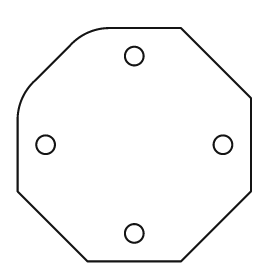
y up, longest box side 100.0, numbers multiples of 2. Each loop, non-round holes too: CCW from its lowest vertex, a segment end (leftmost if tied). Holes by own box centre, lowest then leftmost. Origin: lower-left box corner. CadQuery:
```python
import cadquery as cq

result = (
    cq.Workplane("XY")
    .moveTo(30.0, 0.0)
    .lineTo(70.0, 0.0)
    .lineTo(100.0, 30.0)
    .lineTo(100.0, 70.0)
    .lineTo(70.0, 100.0)
    .lineTo(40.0, 100.0)
    .threePointArc((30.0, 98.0), (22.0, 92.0))
    .lineTo(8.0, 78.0)
    .threePointArc((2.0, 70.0), (0.0, 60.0))
    .lineTo(0.0, 30.0)
    .close()
    .moveTo(50.0, 12.0)
    .circle(4.0)
    .moveTo(12.0, 50.0)
    .circle(4.0)
    .moveTo(88.0, 50.0)
    .circle(4.0)
    .moveTo(50.0, 88.0)
    .circle(4.0)
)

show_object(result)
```